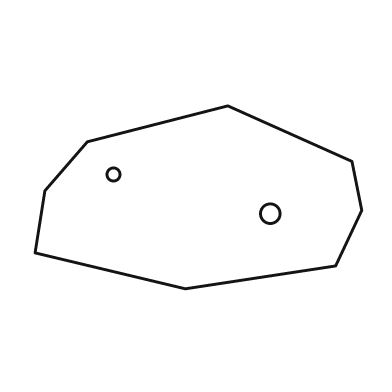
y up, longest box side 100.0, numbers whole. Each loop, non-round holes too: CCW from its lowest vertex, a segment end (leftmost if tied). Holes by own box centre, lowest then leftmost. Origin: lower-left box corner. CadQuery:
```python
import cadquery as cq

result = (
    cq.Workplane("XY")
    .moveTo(46.0, 0.0)
    .lineTo(92.0, 7.0)
    .lineTo(100.0, 24.0)
    .lineTo(97.0, 39.0)
    .lineTo(59.0, 56.0)
    .lineTo(16.0, 45.0)
    .lineTo(3.0, 30.0)
    .lineTo(0.0, 11.0)
    .close()
    .moveTo(72.0, 23.0)
    .circle(3.0)
    .moveTo(24.0, 35.0)
    .circle(2.0)
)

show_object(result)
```